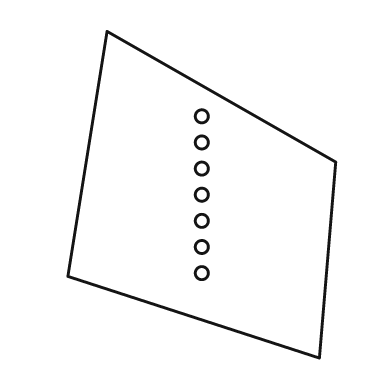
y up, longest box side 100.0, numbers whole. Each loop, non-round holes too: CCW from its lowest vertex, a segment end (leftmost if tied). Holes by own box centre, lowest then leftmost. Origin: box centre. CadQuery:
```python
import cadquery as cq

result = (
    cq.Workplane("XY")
    .moveTo(36.0, -50.0)
    .lineTo(41.0, 10.0)
    .lineTo(-29.0, 50.0)
    .lineTo(-41.0, -25.0)
    .close()
    .moveTo(0.0, -24.0)
    .circle(2.0)
    .moveTo(0.0, -16.0)
    .circle(2.0)
    .moveTo(0.0, -8.0)
    .circle(2.0)
    .moveTo(0.0, 0.0)
    .circle(2.0)
    .moveTo(0.0, 8.0)
    .circle(2.0)
    .moveTo(0.0, 16.0)
    .circle(2.0)
    .moveTo(0.0, 24.0)
    .circle(2.0)
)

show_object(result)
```